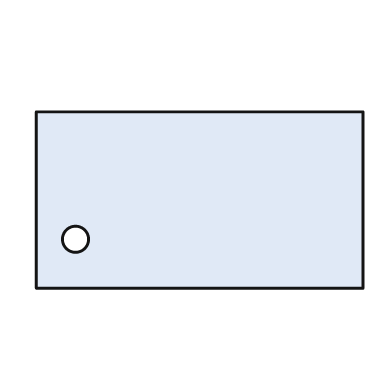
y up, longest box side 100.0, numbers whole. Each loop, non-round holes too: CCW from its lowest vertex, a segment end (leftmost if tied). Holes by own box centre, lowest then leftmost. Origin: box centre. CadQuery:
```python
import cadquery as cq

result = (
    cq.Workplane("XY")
    .moveTo(-50.0, -27.0)
    .lineTo(50.0, -27.0)
    .lineTo(50.0, 27.0)
    .lineTo(-50.0, 27.0)
    .close()
    .moveTo(-38.0, -12.0)
    .circle(4.0)
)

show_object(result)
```